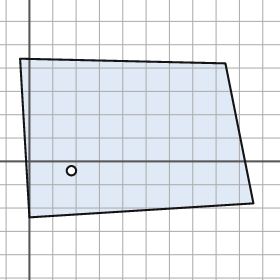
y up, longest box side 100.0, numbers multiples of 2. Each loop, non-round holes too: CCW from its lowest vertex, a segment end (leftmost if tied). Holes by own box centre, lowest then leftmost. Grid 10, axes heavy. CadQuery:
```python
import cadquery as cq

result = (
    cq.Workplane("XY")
    .moveTo(0.0, -24.0)
    .lineTo(96.0, -18.0)
    .lineTo(84.0, 42.0)
    .lineTo(-4.0, 44.0)
    .close()
    .moveTo(18.0, -4.0)
    .circle(2.0)
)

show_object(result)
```